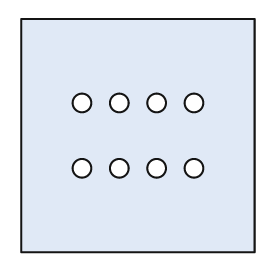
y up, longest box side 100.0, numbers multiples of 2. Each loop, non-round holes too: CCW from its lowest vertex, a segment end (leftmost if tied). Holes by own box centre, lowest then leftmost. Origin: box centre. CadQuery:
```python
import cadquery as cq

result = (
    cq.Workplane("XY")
    .moveTo(-50.0, -50.0)
    .lineTo(50.0, -50.0)
    .lineTo(50.0, 50.0)
    .lineTo(-50.0, 50.0)
    .close()
    .moveTo(-24.0, -14.0)
    .circle(4.0)
    .moveTo(-8.0, -14.0)
    .circle(4.0)
    .moveTo(8.0, -14.0)
    .circle(4.0)
    .moveTo(24.0, -14.0)
    .circle(4.0)
    .moveTo(-24.0, 14.0)
    .circle(4.0)
    .moveTo(-8.0, 14.0)
    .circle(4.0)
    .moveTo(8.0, 14.0)
    .circle(4.0)
    .moveTo(24.0, 14.0)
    .circle(4.0)
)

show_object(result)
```